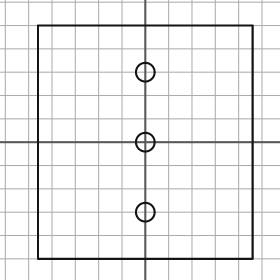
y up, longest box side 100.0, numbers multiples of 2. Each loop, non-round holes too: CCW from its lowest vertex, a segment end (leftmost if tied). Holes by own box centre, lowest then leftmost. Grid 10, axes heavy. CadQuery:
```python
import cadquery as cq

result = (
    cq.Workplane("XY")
    .moveTo(-46.0, -50.0)
    .lineTo(46.0, -50.0)
    .lineTo(46.0, 50.0)
    .lineTo(-46.0, 50.0)
    .close()
    .moveTo(0.0, -30.0)
    .circle(4.0)
    .moveTo(0.0, 0.0)
    .circle(4.0)
    .moveTo(0.0, 30.0)
    .circle(4.0)
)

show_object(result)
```